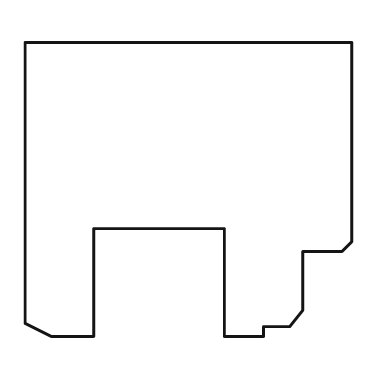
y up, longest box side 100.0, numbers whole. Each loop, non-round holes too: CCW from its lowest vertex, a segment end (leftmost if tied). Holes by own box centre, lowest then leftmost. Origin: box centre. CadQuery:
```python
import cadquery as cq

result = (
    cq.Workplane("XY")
    .moveTo(-42.0, -45.0)
    .lineTo(-29.0, -45.0)
    .lineTo(-29.0, -12.0)
    .lineTo(11.0, -12.0)
    .lineTo(11.0, -45.0)
    .lineTo(23.0, -45.0)
    .lineTo(23.0, -42.0)
    .lineTo(31.0, -42.0)
    .lineTo(35.0, -37.0)
    .lineTo(35.0, -19.0)
    .lineTo(47.0, -19.0)
    .lineTo(50.0, -16.0)
    .lineTo(50.0, 45.0)
    .lineTo(-50.0, 45.0)
    .lineTo(-50.0, -41.0)
    .close()
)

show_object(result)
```